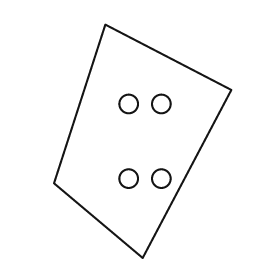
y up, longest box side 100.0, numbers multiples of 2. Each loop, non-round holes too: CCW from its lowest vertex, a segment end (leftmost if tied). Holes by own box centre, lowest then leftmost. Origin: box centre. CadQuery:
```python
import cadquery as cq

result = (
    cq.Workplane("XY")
    .moveTo(0.0, -50.0)
    .lineTo(38.0, 22.0)
    .lineTo(-16.0, 50.0)
    .lineTo(-38.0, -18.0)
    .close()
    .moveTo(-6.0, -16.0)
    .circle(4.0)
    .moveTo(8.0, -16.0)
    .circle(4.0)
    .moveTo(-6.0, 16.0)
    .circle(4.0)
    .moveTo(8.0, 16.0)
    .circle(4.0)
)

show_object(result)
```